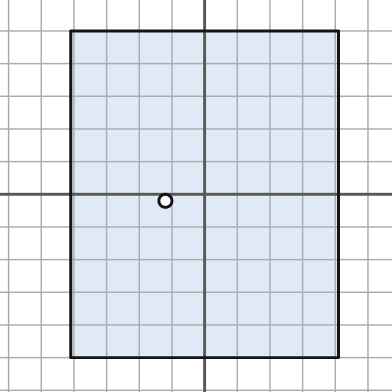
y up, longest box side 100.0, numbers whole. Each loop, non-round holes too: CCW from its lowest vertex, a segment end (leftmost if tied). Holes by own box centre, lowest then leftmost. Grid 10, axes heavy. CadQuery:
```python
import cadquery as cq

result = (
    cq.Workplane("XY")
    .moveTo(-41.0, -50.0)
    .lineTo(41.0, -50.0)
    .lineTo(41.0, 50.0)
    .lineTo(-41.0, 50.0)
    .close()
    .moveTo(-12.0, -2.0)
    .circle(2.0)
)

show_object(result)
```